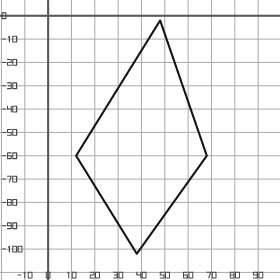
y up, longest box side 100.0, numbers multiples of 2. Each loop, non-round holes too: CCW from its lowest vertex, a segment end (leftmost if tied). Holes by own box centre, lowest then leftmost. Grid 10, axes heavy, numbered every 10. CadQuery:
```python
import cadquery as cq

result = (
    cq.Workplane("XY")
    .moveTo(38.0, -102.0)
    .lineTo(68.0, -60.0)
    .lineTo(48.0, -2.0)
    .lineTo(12.0, -60.0)
    .close()
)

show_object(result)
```